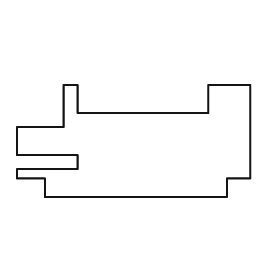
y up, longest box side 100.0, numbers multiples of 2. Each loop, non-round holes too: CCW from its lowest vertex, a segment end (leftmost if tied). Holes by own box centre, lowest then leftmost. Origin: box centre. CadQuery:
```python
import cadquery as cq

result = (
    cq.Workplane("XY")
    .moveTo(-38.0, -24.0)
    .lineTo(40.0, -24.0)
    .lineTo(40.0, -16.0)
    .lineTo(50.0, -16.0)
    .lineTo(50.0, 24.0)
    .lineTo(32.0, 24.0)
    .lineTo(32.0, 12.0)
    .lineTo(-24.0, 12.0)
    .lineTo(-24.0, 24.0)
    .lineTo(-30.0, 24.0)
    .lineTo(-30.0, 6.0)
    .lineTo(-50.0, 6.0)
    .lineTo(-50.0, -6.0)
    .lineTo(-24.0, -6.0)
    .lineTo(-24.0, -12.0)
    .lineTo(-50.0, -12.0)
    .lineTo(-50.0, -16.0)
    .lineTo(-38.0, -16.0)
    .close()
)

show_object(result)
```